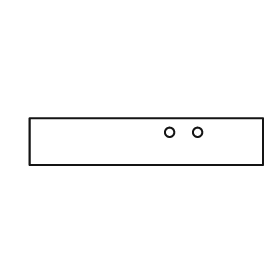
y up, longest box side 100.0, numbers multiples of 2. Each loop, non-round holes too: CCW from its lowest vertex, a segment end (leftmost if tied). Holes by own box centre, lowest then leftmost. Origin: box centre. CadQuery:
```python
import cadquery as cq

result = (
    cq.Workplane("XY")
    .moveTo(-50.0, -10.0)
    .lineTo(50.0, -10.0)
    .lineTo(50.0, 10.0)
    .lineTo(-50.0, 10.0)
    .close()
    .moveTo(10.0, 4.0)
    .circle(2.0)
    .moveTo(22.0, 4.0)
    .circle(2.0)
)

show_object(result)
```